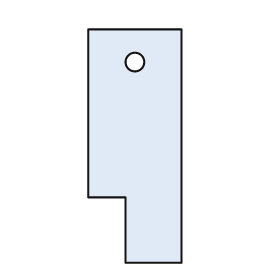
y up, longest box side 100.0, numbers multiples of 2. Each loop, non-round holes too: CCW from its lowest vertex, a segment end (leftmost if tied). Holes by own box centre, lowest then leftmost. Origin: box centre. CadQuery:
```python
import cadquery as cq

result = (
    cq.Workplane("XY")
    .moveTo(-4.0, -50.0)
    .lineTo(20.0, -50.0)
    .lineTo(20.0, 50.0)
    .lineTo(-20.0, 50.0)
    .lineTo(-20.0, -22.0)
    .lineTo(-4.0, -22.0)
    .close()
    .moveTo(0.0, 36.0)
    .circle(4.0)
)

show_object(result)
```